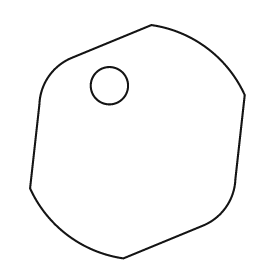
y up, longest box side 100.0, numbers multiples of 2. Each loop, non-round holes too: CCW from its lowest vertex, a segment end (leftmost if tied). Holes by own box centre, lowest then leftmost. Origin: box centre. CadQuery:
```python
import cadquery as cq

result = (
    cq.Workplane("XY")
    .moveTo(-6.0, -50.0)
    .lineTo(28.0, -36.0)
    .threePointArc((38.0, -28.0), (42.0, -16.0))
    .lineTo(46.0, 20.0)
    .threePointArc((30.0, 40.0), (6.0, 50.0))
    .lineTo(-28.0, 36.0)
    .threePointArc((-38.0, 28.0), (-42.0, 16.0))
    .lineTo(-46.0, -20.0)
    .threePointArc((-30.0, -40.0), (-6.0, -50.0))
    .close()
    .moveTo(-12.0, 24.0)
    .circle(8.0)
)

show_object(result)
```